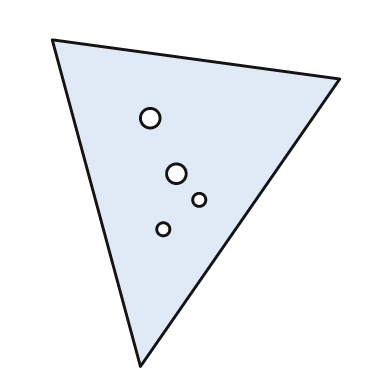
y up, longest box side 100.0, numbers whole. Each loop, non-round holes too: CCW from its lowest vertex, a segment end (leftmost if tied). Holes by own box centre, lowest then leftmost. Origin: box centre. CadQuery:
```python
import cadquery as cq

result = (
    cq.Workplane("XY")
    .moveTo(-17.0, -50.0)
    .lineTo(44.0, 38.0)
    .lineTo(-44.0, 50.0)
    .close()
    .moveTo(-10.0, -8.0)
    .circle(2.0)
    .moveTo(1.0, 1.0)
    .circle(2.0)
    .moveTo(-6.0, 9.0)
    .circle(3.0)
    .moveTo(-14.0, 26.0)
    .circle(3.0)
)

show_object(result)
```